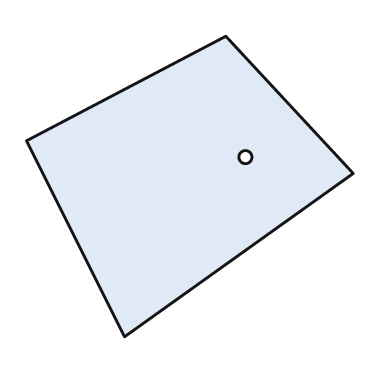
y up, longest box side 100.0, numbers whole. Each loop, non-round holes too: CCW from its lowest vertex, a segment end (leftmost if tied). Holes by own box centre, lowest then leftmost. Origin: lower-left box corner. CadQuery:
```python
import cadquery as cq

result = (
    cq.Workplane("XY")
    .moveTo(30.0, 0.0)
    .lineTo(100.0, 50.0)
    .lineTo(61.0, 92.0)
    .lineTo(0.0, 60.0)
    .close()
    .moveTo(67.0, 55.0)
    .circle(2.0)
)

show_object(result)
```